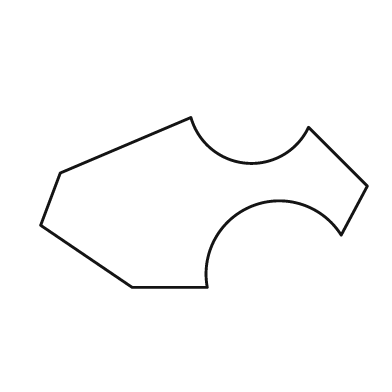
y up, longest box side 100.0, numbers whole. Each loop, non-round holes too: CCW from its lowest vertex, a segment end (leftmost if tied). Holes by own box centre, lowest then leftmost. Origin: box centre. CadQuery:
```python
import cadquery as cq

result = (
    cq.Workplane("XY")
    .moveTo(-22.0, -26.0)
    .lineTo(1.0, -26.0)
    .threePointArc((15.0, -1.0), (42.0, -10.0))
    .lineTo(50.0, 5.0)
    .lineTo(32.0, 23.0)
    .threePointArc((13.0, 12.0), (-4.0, 26.0))
    .lineTo(-44.0, 9.0)
    .lineTo(-50.0, -7.0)
    .close()
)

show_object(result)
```